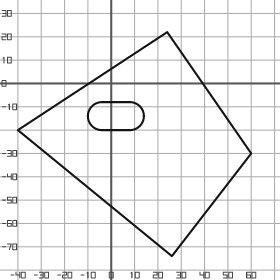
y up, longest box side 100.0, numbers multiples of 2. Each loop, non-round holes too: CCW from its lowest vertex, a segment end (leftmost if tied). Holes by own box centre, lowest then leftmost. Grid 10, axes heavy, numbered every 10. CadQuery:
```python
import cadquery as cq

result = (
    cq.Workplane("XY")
    .moveTo(26.0, -74.0)
    .lineTo(60.0, -30.0)
    .lineTo(24.0, 22.0)
    .lineTo(-40.0, -20.0)
    .close()
    .moveTo(-4.0, -20.0)
    .lineTo(8.0, -20.0)
    .threePointArc((14.0, -14.0), (8.0, -8.0))
    .lineTo(-4.0, -8.0)
    .threePointArc((-10.0, -14.0), (-4.0, -20.0))
    .close()
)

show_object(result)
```